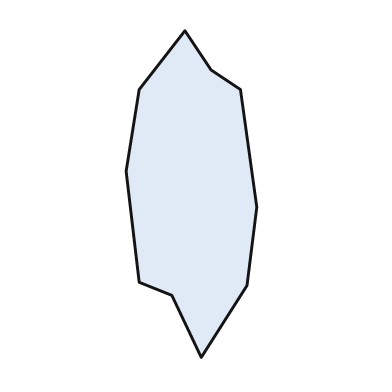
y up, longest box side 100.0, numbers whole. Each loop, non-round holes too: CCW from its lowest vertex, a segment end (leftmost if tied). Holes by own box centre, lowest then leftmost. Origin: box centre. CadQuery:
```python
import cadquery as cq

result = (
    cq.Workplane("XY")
    .moveTo(3.0, -50.0)
    .lineTo(17.0, -28.0)
    .lineTo(20.0, -4.0)
    .lineTo(15.0, 32.0)
    .lineTo(6.0, 38.0)
    .lineTo(-2.0, 50.0)
    .lineTo(-16.0, 32.0)
    .lineTo(-20.0, 7.0)
    .lineTo(-16.0, -27.0)
    .lineTo(-6.0, -31.0)
    .close()
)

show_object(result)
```